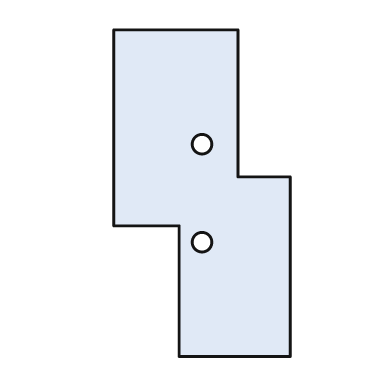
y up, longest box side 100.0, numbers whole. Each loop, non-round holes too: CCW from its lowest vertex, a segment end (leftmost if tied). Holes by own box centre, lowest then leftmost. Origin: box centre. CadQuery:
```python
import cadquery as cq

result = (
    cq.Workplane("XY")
    .moveTo(-7.0, -50.0)
    .lineTo(27.0, -50.0)
    .lineTo(27.0, 5.0)
    .lineTo(11.0, 5.0)
    .lineTo(11.0, 50.0)
    .lineTo(-27.0, 50.0)
    .lineTo(-27.0, -10.0)
    .lineTo(-7.0, -10.0)
    .close()
    .moveTo(0.0, -15.0)
    .circle(3.0)
    .moveTo(0.0, 15.0)
    .circle(3.0)
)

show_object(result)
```